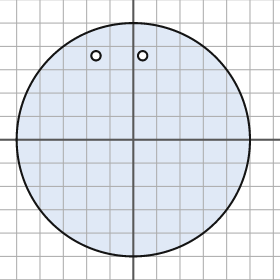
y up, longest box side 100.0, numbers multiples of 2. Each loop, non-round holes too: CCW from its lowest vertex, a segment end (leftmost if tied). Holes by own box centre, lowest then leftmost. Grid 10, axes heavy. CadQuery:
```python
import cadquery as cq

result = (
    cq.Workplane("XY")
    .moveTo(0.0, 0.0)
    .circle(50.0)
    .moveTo(-16.0, 36.0)
    .circle(2.0)
    .moveTo(4.0, 36.0)
    .circle(2.0)
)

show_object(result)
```